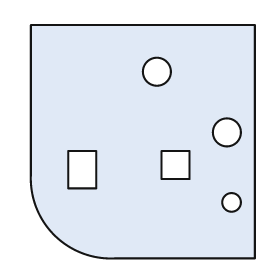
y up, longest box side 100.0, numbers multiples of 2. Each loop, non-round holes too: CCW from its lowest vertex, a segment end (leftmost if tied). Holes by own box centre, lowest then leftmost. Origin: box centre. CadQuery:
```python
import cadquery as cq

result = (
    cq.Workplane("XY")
    .moveTo(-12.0, -50.0)
    .lineTo(48.0, -50.0)
    .lineTo(48.0, 50.0)
    .lineTo(-48.0, 50.0)
    .lineTo(-48.0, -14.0)
    .threePointArc((-38.0, -40.0), (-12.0, -50.0))
    .close()
    .moveTo(38.0, -26.0)
    .circle(4.0)
    .moveTo(-32.0, -20.0)
    .lineTo(-20.0, -20.0)
    .lineTo(-20.0, -4.0)
    .lineTo(-32.0, -4.0)
    .close()
    .moveTo(8.0, -16.0)
    .lineTo(20.0, -16.0)
    .lineTo(20.0, -4.0)
    .lineTo(8.0, -4.0)
    .close()
    .moveTo(36.0, 4.0)
    .circle(6.0)
    .moveTo(6.0, 30.0)
    .circle(6.0)
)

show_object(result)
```